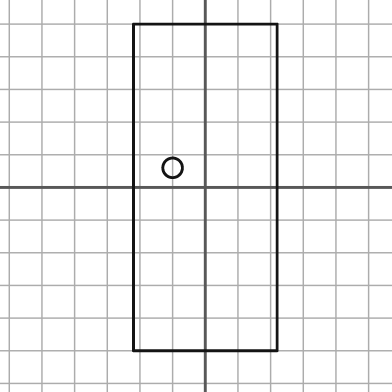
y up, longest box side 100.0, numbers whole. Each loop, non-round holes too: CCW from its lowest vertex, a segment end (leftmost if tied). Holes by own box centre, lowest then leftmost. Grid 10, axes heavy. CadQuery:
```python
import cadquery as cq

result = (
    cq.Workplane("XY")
    .moveTo(-22.0, -50.0)
    .lineTo(22.0, -50.0)
    .lineTo(22.0, 50.0)
    .lineTo(-22.0, 50.0)
    .close()
    .moveTo(-10.0, 6.0)
    .circle(3.0)
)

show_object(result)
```